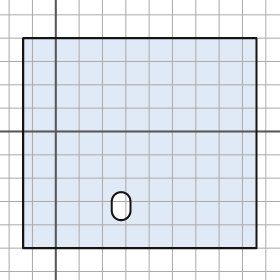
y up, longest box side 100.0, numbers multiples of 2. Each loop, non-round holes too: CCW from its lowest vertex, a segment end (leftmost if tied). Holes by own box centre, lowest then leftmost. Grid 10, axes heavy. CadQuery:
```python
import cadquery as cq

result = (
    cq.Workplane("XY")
    .moveTo(-14.0, -50.0)
    .lineTo(86.0, -50.0)
    .lineTo(86.0, 40.0)
    .lineTo(-14.0, 40.0)
    .close()
    .moveTo(24.0, -34.0)
    .threePointArc((28.0, -38.0), (32.0, -34.0))
    .lineTo(32.0, -30.0)
    .threePointArc((28.0, -26.0), (24.0, -30.0))
    .close()
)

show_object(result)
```